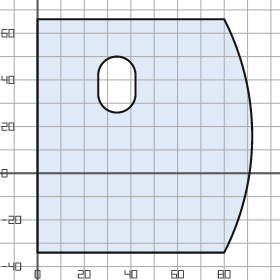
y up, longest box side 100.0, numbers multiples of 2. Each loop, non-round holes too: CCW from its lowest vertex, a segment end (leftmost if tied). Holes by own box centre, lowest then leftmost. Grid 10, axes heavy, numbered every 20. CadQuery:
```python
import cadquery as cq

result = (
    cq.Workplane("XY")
    .moveTo(0.0, -34.0)
    .lineTo(80.0, -34.0)
    .threePointArc((92.0, 16.0), (80.0, 66.0))
    .lineTo(0.0, 66.0)
    .close()
    .moveTo(26.0, 34.0)
    .threePointArc((34.0, 26.0), (42.0, 34.0))
    .lineTo(42.0, 42.0)
    .threePointArc((34.0, 50.0), (26.0, 42.0))
    .close()
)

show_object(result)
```